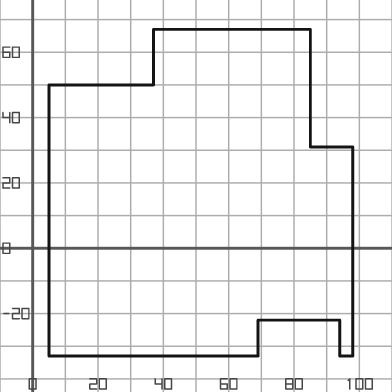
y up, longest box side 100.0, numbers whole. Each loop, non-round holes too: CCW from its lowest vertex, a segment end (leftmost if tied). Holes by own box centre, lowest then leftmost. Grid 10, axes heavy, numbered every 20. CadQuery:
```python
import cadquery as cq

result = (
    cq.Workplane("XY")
    .moveTo(5.0, -33.0)
    .lineTo(69.0, -33.0)
    .lineTo(69.0, -22.0)
    .lineTo(94.0, -22.0)
    .lineTo(94.0, -33.0)
    .lineTo(98.0, -33.0)
    .lineTo(98.0, 31.0)
    .lineTo(85.0, 31.0)
    .lineTo(85.0, 67.0)
    .lineTo(37.0, 67.0)
    .lineTo(37.0, 50.0)
    .lineTo(5.0, 50.0)
    .close()
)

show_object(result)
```